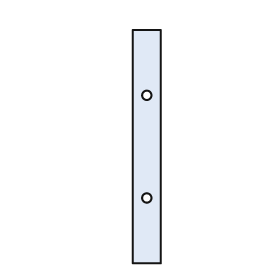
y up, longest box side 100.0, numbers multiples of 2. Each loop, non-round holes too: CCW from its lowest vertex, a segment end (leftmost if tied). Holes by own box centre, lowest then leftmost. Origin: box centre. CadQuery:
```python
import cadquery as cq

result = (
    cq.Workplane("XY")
    .moveTo(-6.0, -50.0)
    .lineTo(6.0, -50.0)
    .lineTo(6.0, 50.0)
    .lineTo(-6.0, 50.0)
    .close()
    .moveTo(0.0, -22.0)
    .circle(2.0)
    .moveTo(0.0, 22.0)
    .circle(2.0)
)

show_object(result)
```